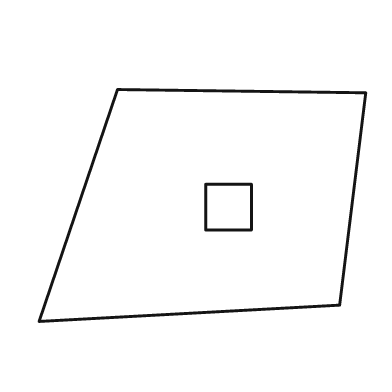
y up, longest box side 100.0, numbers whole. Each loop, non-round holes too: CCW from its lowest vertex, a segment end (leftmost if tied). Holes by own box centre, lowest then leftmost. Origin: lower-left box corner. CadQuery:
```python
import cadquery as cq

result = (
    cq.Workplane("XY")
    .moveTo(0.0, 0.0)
    .lineTo(92.0, 5.0)
    .lineTo(100.0, 70.0)
    .lineTo(24.0, 71.0)
    .close()
    .moveTo(51.0, 28.0)
    .lineTo(65.0, 28.0)
    .lineTo(65.0, 42.0)
    .lineTo(51.0, 42.0)
    .close()
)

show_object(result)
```